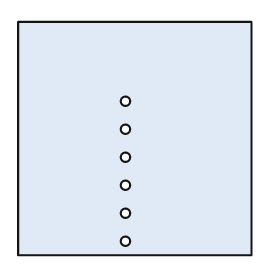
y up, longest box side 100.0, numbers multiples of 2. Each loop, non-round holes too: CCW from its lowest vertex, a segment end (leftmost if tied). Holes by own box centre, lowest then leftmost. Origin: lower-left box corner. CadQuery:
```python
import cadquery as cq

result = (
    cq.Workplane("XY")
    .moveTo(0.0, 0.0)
    .lineTo(100.0, 0.0)
    .lineTo(100.0, 100.0)
    .lineTo(0.0, 100.0)
    .close()
    .moveTo(46.0, 6.0)
    .circle(2.0)
    .moveTo(46.0, 18.0)
    .circle(2.0)
    .moveTo(46.0, 30.0)
    .circle(2.0)
    .moveTo(46.0, 42.0)
    .circle(2.0)
    .moveTo(46.0, 54.0)
    .circle(2.0)
    .moveTo(46.0, 66.0)
    .circle(2.0)
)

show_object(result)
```